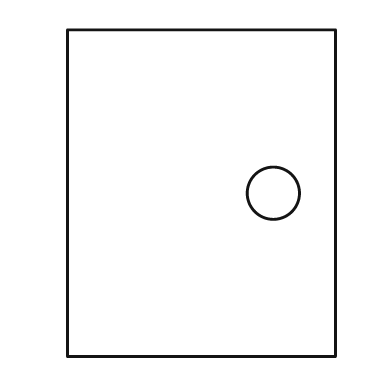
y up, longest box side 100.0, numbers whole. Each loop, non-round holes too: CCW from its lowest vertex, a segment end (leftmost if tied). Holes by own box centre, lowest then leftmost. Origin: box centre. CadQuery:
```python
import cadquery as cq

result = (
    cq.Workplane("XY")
    .moveTo(-41.0, -50.0)
    .lineTo(41.0, -50.0)
    .lineTo(41.0, 50.0)
    .lineTo(-41.0, 50.0)
    .close()
    .moveTo(22.0, 0.0)
    .circle(8.0)
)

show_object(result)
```